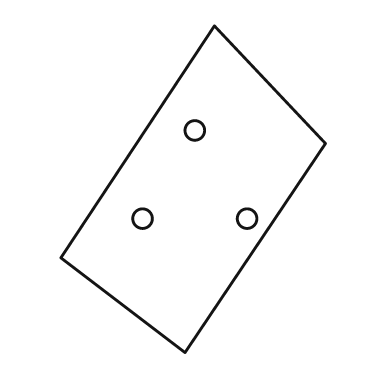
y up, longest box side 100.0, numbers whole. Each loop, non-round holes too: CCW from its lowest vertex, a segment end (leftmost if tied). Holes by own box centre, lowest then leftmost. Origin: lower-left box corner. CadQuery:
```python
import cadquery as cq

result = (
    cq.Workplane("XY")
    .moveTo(38.0, 0.0)
    .lineTo(81.0, 64.0)
    .lineTo(47.0, 100.0)
    .lineTo(0.0, 29.0)
    .close()
    .moveTo(25.0, 41.0)
    .circle(3.0)
    .moveTo(57.0, 41.0)
    .circle(3.0)
    .moveTo(41.0, 68.0)
    .circle(3.0)
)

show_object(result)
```